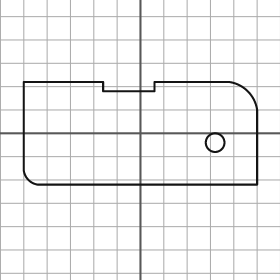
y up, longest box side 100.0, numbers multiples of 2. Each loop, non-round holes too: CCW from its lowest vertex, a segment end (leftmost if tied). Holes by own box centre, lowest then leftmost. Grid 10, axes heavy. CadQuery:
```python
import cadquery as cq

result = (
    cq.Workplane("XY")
    .moveTo(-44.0, -22.0)
    .lineTo(50.0, -22.0)
    .lineTo(50.0, 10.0)
    .threePointArc((46.0, 18.0), (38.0, 22.0))
    .lineTo(6.0, 22.0)
    .lineTo(6.0, 18.0)
    .lineTo(-16.0, 18.0)
    .lineTo(-16.0, 22.0)
    .lineTo(-50.0, 22.0)
    .lineTo(-50.0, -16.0)
    .threePointArc((-48.0, -20.0), (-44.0, -22.0))
    .close()
    .moveTo(32.0, -4.0)
    .circle(4.0)
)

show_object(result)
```